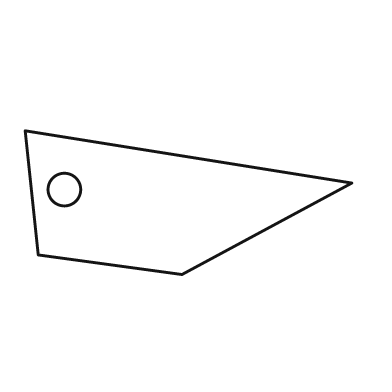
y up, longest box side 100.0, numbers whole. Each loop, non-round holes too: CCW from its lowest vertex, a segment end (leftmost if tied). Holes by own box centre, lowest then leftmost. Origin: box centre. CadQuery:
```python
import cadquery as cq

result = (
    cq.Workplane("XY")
    .moveTo(-2.0, -22.0)
    .lineTo(50.0, 6.0)
    .lineTo(-50.0, 22.0)
    .lineTo(-46.0, -16.0)
    .close()
    .moveTo(-38.0, 4.0)
    .circle(5.0)
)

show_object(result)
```